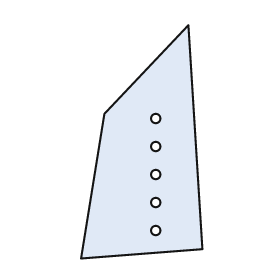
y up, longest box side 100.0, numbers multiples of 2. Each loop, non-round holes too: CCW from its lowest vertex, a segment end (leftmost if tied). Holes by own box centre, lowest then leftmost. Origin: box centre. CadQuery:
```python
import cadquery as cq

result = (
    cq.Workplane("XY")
    .moveTo(-26.0, -50.0)
    .lineTo(26.0, -46.0)
    .lineTo(20.0, 50.0)
    .lineTo(-16.0, 12.0)
    .close()
    .moveTo(6.0, -38.0)
    .circle(2.0)
    .moveTo(6.0, -26.0)
    .circle(2.0)
    .moveTo(6.0, -14.0)
    .circle(2.0)
    .moveTo(6.0, -2.0)
    .circle(2.0)
    .moveTo(6.0, 10.0)
    .circle(2.0)
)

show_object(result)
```